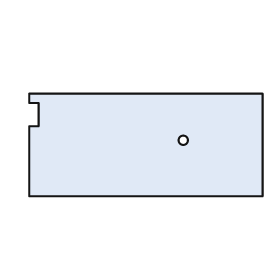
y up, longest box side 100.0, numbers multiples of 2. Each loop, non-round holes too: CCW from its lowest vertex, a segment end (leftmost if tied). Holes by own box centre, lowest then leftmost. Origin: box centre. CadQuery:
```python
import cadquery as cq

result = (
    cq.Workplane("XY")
    .moveTo(-50.0, -22.0)
    .lineTo(50.0, -22.0)
    .lineTo(50.0, 22.0)
    .lineTo(-50.0, 22.0)
    .lineTo(-50.0, 18.0)
    .lineTo(-46.0, 18.0)
    .lineTo(-46.0, 8.0)
    .lineTo(-50.0, 8.0)
    .close()
    .moveTo(16.0, 2.0)
    .circle(2.0)
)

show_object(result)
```